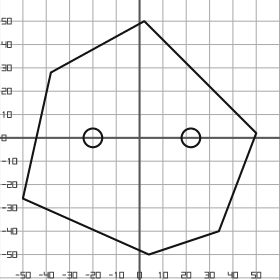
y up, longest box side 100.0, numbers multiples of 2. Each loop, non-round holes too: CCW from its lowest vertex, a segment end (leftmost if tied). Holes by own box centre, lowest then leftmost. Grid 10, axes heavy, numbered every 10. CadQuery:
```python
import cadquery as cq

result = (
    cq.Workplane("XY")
    .moveTo(4.0, -50.0)
    .lineTo(34.0, -40.0)
    .lineTo(50.0, 2.0)
    .lineTo(2.0, 50.0)
    .lineTo(-38.0, 28.0)
    .lineTo(-50.0, -26.0)
    .close()
    .moveTo(-20.0, 0.0)
    .circle(4.0)
    .moveTo(22.0, 0.0)
    .circle(4.0)
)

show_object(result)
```